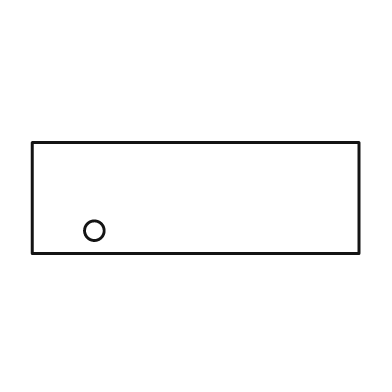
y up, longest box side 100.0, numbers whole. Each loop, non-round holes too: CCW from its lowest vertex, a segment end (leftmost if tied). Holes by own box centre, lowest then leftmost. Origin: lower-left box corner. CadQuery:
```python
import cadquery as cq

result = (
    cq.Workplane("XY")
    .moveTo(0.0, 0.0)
    .lineTo(100.0, 0.0)
    .lineTo(100.0, 34.0)
    .lineTo(0.0, 34.0)
    .close()
    .moveTo(19.0, 7.0)
    .circle(3.0)
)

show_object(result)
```